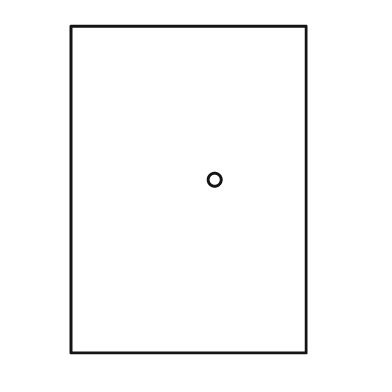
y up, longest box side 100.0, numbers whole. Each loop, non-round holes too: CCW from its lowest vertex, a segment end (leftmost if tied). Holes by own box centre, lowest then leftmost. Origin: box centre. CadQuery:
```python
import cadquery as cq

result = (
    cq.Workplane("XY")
    .moveTo(-36.0, -50.0)
    .lineTo(36.0, -50.0)
    .lineTo(36.0, 50.0)
    .lineTo(-36.0, 50.0)
    .close()
    .moveTo(8.0, 3.0)
    .circle(2.0)
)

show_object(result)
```